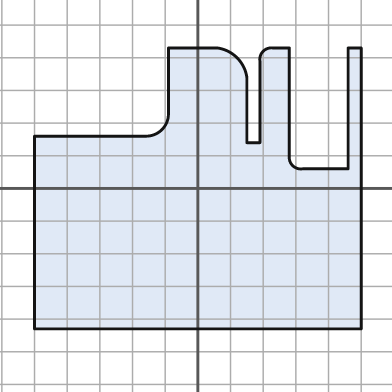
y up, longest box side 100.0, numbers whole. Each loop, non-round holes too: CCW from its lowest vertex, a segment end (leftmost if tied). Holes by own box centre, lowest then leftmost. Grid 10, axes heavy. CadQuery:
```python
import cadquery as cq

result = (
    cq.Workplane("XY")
    .moveTo(-50.0, -43.0)
    .lineTo(50.0, -43.0)
    .lineTo(50.0, 43.0)
    .lineTo(46.0, 43.0)
    .lineTo(46.0, 6.0)
    .lineTo(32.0, 6.0)
    .threePointArc((29.0, 7.0), (28.0, 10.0))
    .lineTo(28.0, 43.0)
    .lineTo(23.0, 43.0)
    .threePointArc((20.0, 42.0), (19.0, 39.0))
    .lineTo(19.0, 14.0)
    .lineTo(15.0, 14.0)
    .lineTo(15.0, 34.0)
    .threePointArc((12.0, 40.0), (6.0, 43.0))
    .lineTo(-9.0, 43.0)
    .lineTo(-9.0, 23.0)
    .threePointArc((-11.0, 18.0), (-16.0, 16.0))
    .lineTo(-50.0, 16.0)
    .close()
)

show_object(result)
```